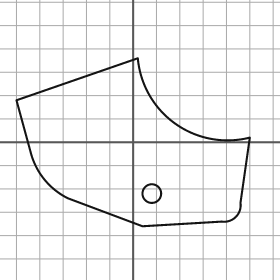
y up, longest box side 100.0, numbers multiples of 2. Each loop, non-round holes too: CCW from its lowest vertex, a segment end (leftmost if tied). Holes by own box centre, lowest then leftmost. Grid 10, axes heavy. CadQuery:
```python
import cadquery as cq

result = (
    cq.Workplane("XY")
    .moveTo(4.0, -36.0)
    .lineTo(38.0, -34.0)
    .threePointArc((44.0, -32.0), (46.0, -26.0))
    .lineTo(50.0, 2.0)
    .threePointArc((18.0, 8.0), (2.0, 36.0))
    .lineTo(-50.0, 18.0)
    .lineTo(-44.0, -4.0)
    .threePointArc((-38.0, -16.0), (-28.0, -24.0))
    .close()
    .moveTo(8.0, -22.0)
    .circle(4.0)
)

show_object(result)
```